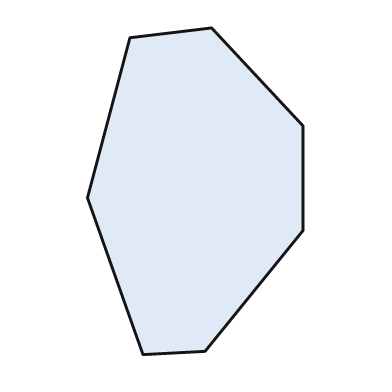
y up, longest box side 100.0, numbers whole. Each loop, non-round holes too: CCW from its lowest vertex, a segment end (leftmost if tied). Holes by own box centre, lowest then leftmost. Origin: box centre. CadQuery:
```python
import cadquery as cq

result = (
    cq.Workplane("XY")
    .moveTo(-16.0, -50.0)
    .lineTo(3.0, -49.0)
    .lineTo(33.0, -12.0)
    .lineTo(33.0, 20.0)
    .lineTo(5.0, 50.0)
    .lineTo(-20.0, 47.0)
    .lineTo(-33.0, -2.0)
    .close()
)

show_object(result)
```